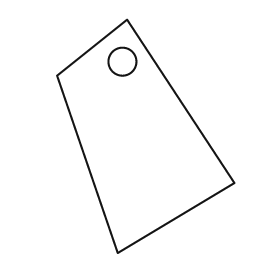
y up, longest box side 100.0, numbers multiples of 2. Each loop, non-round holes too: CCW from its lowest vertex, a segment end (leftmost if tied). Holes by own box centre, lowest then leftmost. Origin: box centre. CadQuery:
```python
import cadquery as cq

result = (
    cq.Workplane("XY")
    .moveTo(-12.0, -50.0)
    .lineTo(38.0, -20.0)
    .lineTo(-8.0, 50.0)
    .lineTo(-38.0, 26.0)
    .close()
    .moveTo(-10.0, 32.0)
    .circle(6.0)
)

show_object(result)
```